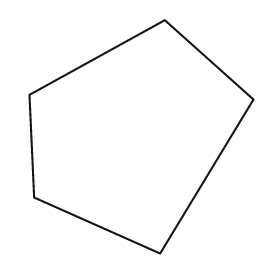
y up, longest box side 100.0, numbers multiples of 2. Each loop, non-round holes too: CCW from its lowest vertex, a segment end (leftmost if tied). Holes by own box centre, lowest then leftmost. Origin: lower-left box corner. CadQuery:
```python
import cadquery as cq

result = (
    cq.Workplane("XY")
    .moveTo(56.0, 0.0)
    .lineTo(96.0, 66.0)
    .lineTo(58.0, 100.0)
    .lineTo(0.0, 68.0)
    .lineTo(2.0, 24.0)
    .close()
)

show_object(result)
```